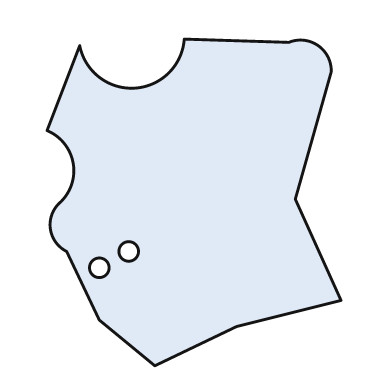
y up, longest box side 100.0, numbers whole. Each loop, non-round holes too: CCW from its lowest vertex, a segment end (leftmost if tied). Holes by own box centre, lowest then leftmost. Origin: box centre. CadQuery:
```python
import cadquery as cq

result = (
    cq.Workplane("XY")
    .moveTo(-12.0, -50.0)
    .lineTo(13.0, -38.0)
    .lineTo(45.0, -30.0)
    .lineTo(31.0, 1.0)
    .lineTo(42.0, 40.0)
    .threePointArc((38.0, 48.0), (29.0, 49.0))
    .lineTo(-3.0, 50.0)
    .threePointArc((-18.0, 35.0), (-35.0, 48.0))
    .lineTo(-45.0, 22.0)
    .threePointArc((-37.0, 12.0), (-41.0, 0.0))
    .threePointArc((-44.0, -8.0), (-39.0, -15.0))
    .lineTo(-29.0, -36.0)
    .close()
    .moveTo(-29.0, -20.0)
    .circle(3.0)
    .moveTo(-20.0, -15.0)
    .circle(3.0)
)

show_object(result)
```